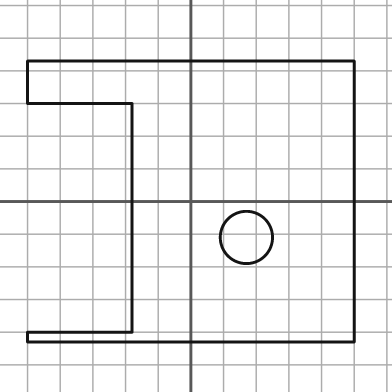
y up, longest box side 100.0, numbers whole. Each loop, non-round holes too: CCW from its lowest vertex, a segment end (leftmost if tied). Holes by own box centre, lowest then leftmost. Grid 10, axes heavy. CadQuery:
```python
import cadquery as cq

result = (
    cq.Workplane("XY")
    .moveTo(-50.0, -43.0)
    .lineTo(50.0, -43.0)
    .lineTo(50.0, 43.0)
    .lineTo(-50.0, 43.0)
    .lineTo(-50.0, 30.0)
    .lineTo(-18.0, 30.0)
    .lineTo(-18.0, -40.0)
    .lineTo(-50.0, -40.0)
    .close()
    .moveTo(17.0, -11.0)
    .circle(8.0)
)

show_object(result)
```